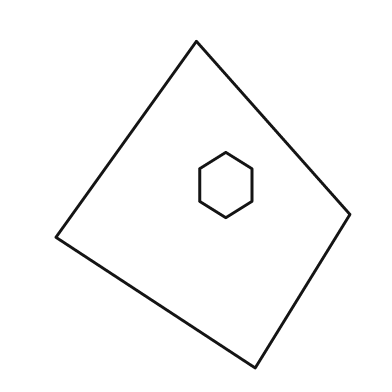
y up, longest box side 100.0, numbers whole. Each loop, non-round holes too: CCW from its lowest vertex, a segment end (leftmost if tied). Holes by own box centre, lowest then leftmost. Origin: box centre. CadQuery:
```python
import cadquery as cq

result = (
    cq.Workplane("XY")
    .moveTo(16.0, -50.0)
    .lineTo(45.0, -3.0)
    .lineTo(-2.0, 50.0)
    .lineTo(-45.0, -10.0)
    .close()
    .moveTo(7.0, -4.0)
    .lineTo(15.0, 1.0)
    .lineTo(15.0, 11.0)
    .lineTo(7.0, 16.0)
    .lineTo(-1.0, 11.0)
    .lineTo(-1.0, 1.0)
    .close()
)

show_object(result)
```